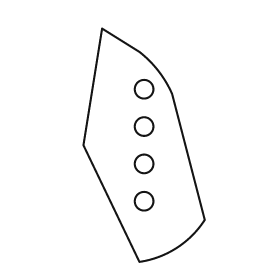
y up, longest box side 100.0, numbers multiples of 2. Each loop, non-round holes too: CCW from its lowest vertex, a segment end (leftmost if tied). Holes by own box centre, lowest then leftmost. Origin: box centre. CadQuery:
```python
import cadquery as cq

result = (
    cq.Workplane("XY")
    .moveTo(-2.0, -50.0)
    .threePointArc((14.0, -44.0), (26.0, -32.0))
    .lineTo(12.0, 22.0)
    .threePointArc((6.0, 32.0), (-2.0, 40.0))
    .lineTo(-18.0, 50.0)
    .lineTo(-26.0, 0.0)
    .close()
    .moveTo(0.0, -24.0)
    .circle(4.0)
    .moveTo(0.0, -8.0)
    .circle(4.0)
    .moveTo(0.0, 8.0)
    .circle(4.0)
    .moveTo(0.0, 24.0)
    .circle(4.0)
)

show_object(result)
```